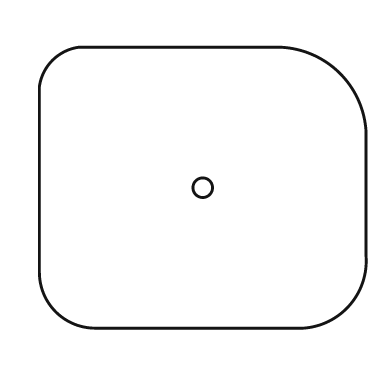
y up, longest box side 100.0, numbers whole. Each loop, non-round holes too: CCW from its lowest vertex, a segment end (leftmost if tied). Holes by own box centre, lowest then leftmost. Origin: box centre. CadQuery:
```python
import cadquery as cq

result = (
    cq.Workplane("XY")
    .moveTo(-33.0, -43.0)
    .lineTo(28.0, -43.0)
    .threePointArc((44.0, -37.0), (50.0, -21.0))
    .lineTo(50.0, 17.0)
    .threePointArc((42.0, 35.0), (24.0, 43.0))
    .lineTo(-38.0, 43.0)
    .threePointArc((-46.0, 39.0), (-50.0, 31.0))
    .lineTo(-50.0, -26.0)
    .threePointArc((-45.0, -38.0), (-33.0, -43.0))
    .close()
    .moveTo(0.0, 0.0)
    .circle(3.0)
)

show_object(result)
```